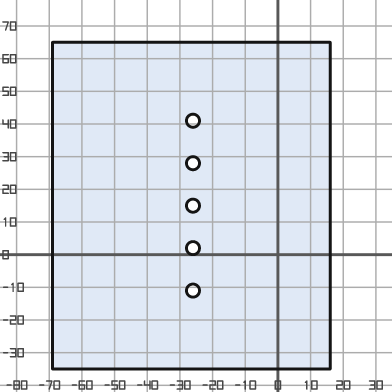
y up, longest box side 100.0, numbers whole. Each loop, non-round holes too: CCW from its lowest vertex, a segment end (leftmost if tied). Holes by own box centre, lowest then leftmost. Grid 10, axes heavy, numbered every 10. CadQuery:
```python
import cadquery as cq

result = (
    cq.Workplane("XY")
    .moveTo(-69.0, -35.0)
    .lineTo(16.0, -35.0)
    .lineTo(16.0, 65.0)
    .lineTo(-69.0, 65.0)
    .close()
    .moveTo(-26.0, -11.0)
    .circle(2.0)
    .moveTo(-26.0, 2.0)
    .circle(2.0)
    .moveTo(-26.0, 15.0)
    .circle(2.0)
    .moveTo(-26.0, 28.0)
    .circle(2.0)
    .moveTo(-26.0, 41.0)
    .circle(2.0)
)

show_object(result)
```